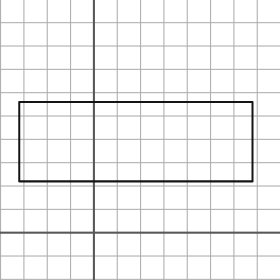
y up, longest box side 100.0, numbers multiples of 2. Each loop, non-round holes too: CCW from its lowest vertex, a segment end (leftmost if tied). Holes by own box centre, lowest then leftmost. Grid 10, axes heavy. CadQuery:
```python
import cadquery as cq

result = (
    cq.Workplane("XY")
    .moveTo(-32.0, 22.0)
    .lineTo(68.0, 22.0)
    .lineTo(68.0, 56.0)
    .lineTo(-32.0, 56.0)
    .close()
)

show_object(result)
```